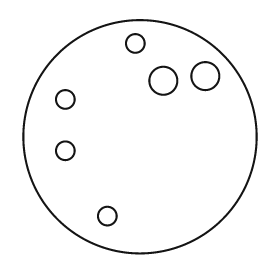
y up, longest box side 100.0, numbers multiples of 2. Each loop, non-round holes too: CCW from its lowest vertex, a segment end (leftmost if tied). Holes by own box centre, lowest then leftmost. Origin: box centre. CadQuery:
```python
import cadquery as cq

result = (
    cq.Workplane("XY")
    .moveTo(0.0, 0.0)
    .circle(50.0)
    .moveTo(-14.0, -34.0)
    .circle(4.0)
    .moveTo(-32.0, -6.0)
    .circle(4.0)
    .moveTo(-32.0, 16.0)
    .circle(4.0)
    .moveTo(10.0, 24.0)
    .circle(6.0)
    .moveTo(28.0, 26.0)
    .circle(6.0)
    .moveTo(-2.0, 40.0)
    .circle(4.0)
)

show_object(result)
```